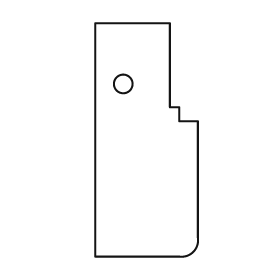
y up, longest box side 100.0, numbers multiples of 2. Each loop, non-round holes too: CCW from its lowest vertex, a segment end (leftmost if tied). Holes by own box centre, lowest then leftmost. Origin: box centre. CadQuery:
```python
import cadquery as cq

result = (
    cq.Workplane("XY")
    .moveTo(-22.0, -50.0)
    .lineTo(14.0, -50.0)
    .threePointArc((20.0, -48.0), (22.0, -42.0))
    .lineTo(22.0, 8.0)
    .lineTo(14.0, 8.0)
    .lineTo(14.0, 14.0)
    .lineTo(10.0, 14.0)
    .lineTo(10.0, 50.0)
    .lineTo(-22.0, 50.0)
    .close()
    .moveTo(-10.0, 24.0)
    .circle(4.0)
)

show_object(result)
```